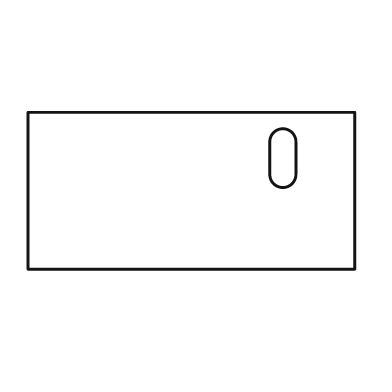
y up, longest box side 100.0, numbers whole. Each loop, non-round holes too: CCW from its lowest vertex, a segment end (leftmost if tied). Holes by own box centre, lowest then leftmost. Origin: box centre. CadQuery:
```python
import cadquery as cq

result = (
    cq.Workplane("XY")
    .moveTo(-50.0, -24.0)
    .lineTo(50.0, -24.0)
    .lineTo(50.0, 24.0)
    .lineTo(-50.0, 24.0)
    .close()
    .moveTo(24.0, 5.0)
    .threePointArc((28.0, 1.0), (32.0, 5.0))
    .lineTo(32.0, 15.0)
    .threePointArc((28.0, 19.0), (24.0, 15.0))
    .close()
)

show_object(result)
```